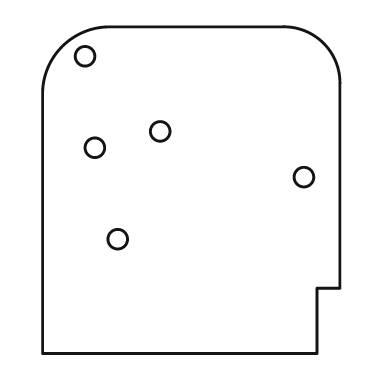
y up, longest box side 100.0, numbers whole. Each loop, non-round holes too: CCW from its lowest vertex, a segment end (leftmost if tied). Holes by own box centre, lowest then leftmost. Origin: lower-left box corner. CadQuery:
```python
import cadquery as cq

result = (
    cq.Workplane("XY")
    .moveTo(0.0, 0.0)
    .lineTo(84.0, 0.0)
    .lineTo(84.0, 20.0)
    .lineTo(91.0, 20.0)
    .lineTo(91.0, 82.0)
    .threePointArc((86.0, 95.0), (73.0, 100.0))
    .lineTo(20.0, 100.0)
    .threePointArc((6.0, 94.0), (0.0, 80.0))
    .close()
    .moveTo(23.0, 35.0)
    .circle(3.0)
    .moveTo(80.0, 54.0)
    .circle(3.0)
    .moveTo(16.0, 63.0)
    .circle(3.0)
    .moveTo(36.0, 68.0)
    .circle(3.0)
    .moveTo(13.0, 91.0)
    .circle(3.0)
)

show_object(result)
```